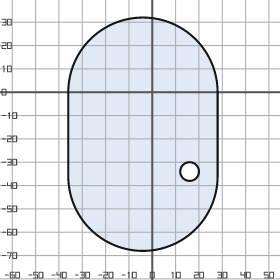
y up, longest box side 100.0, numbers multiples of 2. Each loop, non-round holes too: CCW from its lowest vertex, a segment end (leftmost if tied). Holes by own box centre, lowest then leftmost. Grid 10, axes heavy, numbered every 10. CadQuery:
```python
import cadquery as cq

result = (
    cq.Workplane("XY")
    .moveTo(-36.0, -36.0)
    .threePointArc((-4.0, -68.0), (28.0, -36.0))
    .lineTo(28.0, 0.0)
    .threePointArc((-4.0, 32.0), (-36.0, 0.0))
    .close()
    .moveTo(16.0, -34.0)
    .circle(4.0)
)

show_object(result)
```